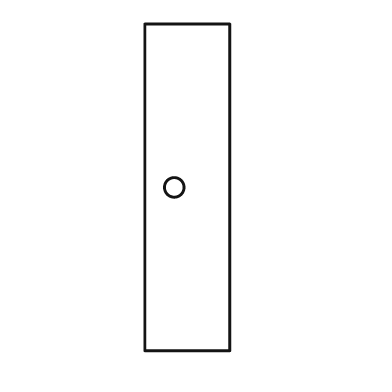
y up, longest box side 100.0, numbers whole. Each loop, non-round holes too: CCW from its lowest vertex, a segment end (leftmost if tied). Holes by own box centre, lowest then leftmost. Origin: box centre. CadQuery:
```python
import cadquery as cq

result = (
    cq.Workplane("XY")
    .moveTo(-13.0, -50.0)
    .lineTo(13.0, -50.0)
    .lineTo(13.0, 50.0)
    .lineTo(-13.0, 50.0)
    .close()
    .moveTo(-4.0, 0.0)
    .circle(3.0)
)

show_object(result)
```